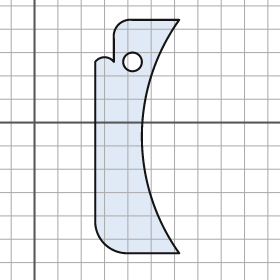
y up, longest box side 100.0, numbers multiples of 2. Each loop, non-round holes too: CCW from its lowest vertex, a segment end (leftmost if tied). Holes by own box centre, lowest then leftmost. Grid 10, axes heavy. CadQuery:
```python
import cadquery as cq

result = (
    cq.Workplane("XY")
    .moveTo(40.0, -56.0)
    .lineTo(62.0, -56.0)
    .threePointArc((46.0, -6.0), (62.0, 44.0))
    .lineTo(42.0, 44.0)
    .threePointArc((36.0, 42.0), (34.0, 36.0))
    .lineTo(34.0, 26.0)
    .threePointArc((30.0, 28.0), (26.0, 26.0))
    .lineTo(26.0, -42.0)
    .threePointArc((30.0, -52.0), (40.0, -56.0))
    .close()
    .moveTo(42.0, 26.0)
    .circle(4.0)
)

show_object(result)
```